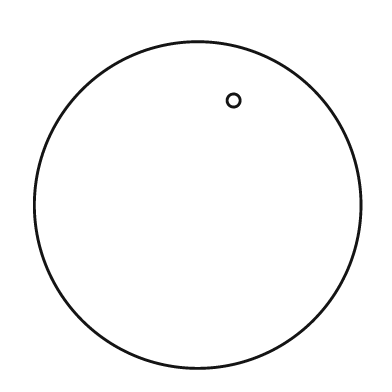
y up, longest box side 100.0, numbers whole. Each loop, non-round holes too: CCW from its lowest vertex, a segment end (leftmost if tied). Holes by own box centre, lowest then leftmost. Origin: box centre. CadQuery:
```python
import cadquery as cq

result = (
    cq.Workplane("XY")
    .moveTo(0.0, 0.0)
    .circle(50.0)
    .moveTo(11.0, 32.0)
    .circle(2.0)
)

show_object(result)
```